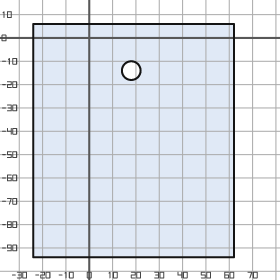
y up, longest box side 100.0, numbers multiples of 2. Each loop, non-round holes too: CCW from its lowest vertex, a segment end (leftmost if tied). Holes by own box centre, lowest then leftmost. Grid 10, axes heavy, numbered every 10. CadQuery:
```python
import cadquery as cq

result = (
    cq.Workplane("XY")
    .moveTo(-24.0, -94.0)
    .lineTo(62.0, -94.0)
    .lineTo(62.0, 6.0)
    .lineTo(-24.0, 6.0)
    .close()
    .moveTo(18.0, -14.0)
    .circle(4.0)
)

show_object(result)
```